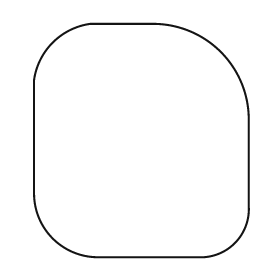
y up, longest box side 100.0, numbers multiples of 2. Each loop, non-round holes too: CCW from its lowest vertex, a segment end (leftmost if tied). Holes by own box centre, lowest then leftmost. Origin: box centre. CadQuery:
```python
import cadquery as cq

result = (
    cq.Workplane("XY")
    .moveTo(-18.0, -50.0)
    .lineTo(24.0, -50.0)
    .threePointArc((40.0, -44.0), (46.0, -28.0))
    .lineTo(46.0, 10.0)
    .threePointArc((34.0, 38.0), (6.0, 50.0))
    .lineTo(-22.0, 50.0)
    .threePointArc((-38.0, 42.0), (-46.0, 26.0))
    .lineTo(-46.0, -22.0)
    .threePointArc((-38.0, -42.0), (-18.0, -50.0))
    .close()
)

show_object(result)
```